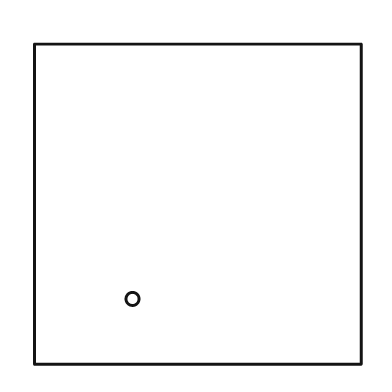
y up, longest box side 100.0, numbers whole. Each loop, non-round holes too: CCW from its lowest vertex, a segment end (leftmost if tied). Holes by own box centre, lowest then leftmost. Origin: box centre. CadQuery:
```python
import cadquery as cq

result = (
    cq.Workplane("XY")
    .moveTo(-50.0, -49.0)
    .lineTo(50.0, -49.0)
    .lineTo(50.0, 49.0)
    .lineTo(-50.0, 49.0)
    .close()
    .moveTo(-20.0, -29.0)
    .circle(2.0)
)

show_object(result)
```